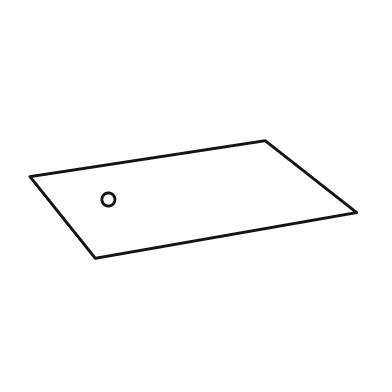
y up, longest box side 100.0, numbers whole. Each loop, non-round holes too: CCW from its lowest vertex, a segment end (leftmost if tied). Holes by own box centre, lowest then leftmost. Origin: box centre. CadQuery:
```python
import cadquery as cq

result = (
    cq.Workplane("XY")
    .moveTo(-30.0, -18.0)
    .lineTo(50.0, -4.0)
    .lineTo(22.0, 18.0)
    .lineTo(-50.0, 7.0)
    .close()
    .moveTo(-26.0, 0.0)
    .circle(2.0)
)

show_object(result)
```